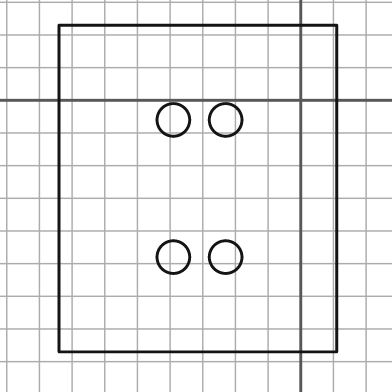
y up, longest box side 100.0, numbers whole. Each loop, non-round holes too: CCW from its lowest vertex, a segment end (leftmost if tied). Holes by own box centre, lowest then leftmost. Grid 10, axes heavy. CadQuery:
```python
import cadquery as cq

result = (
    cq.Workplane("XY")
    .moveTo(-74.0, -77.0)
    .lineTo(11.0, -77.0)
    .lineTo(11.0, 23.0)
    .lineTo(-74.0, 23.0)
    .close()
    .moveTo(-39.0, -48.0)
    .circle(5.0)
    .moveTo(-23.0, -48.0)
    .circle(5.0)
    .moveTo(-39.0, -6.0)
    .circle(5.0)
    .moveTo(-23.0, -6.0)
    .circle(5.0)
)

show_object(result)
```